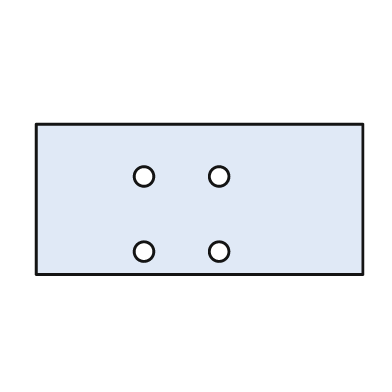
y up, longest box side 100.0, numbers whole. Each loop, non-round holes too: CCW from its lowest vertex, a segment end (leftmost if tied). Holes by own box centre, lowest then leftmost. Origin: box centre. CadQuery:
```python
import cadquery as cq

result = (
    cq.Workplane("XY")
    .moveTo(-50.0, -23.0)
    .lineTo(50.0, -23.0)
    .lineTo(50.0, 23.0)
    .lineTo(-50.0, 23.0)
    .close()
    .moveTo(-17.0, -16.0)
    .circle(3.0)
    .moveTo(6.0, -16.0)
    .circle(3.0)
    .moveTo(-17.0, 7.0)
    .circle(3.0)
    .moveTo(6.0, 7.0)
    .circle(3.0)
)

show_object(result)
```